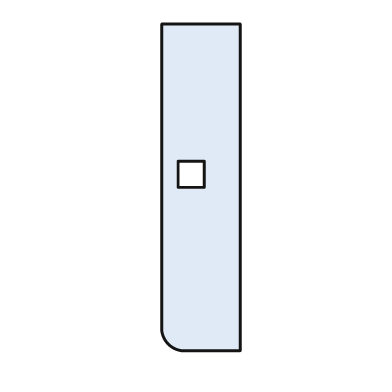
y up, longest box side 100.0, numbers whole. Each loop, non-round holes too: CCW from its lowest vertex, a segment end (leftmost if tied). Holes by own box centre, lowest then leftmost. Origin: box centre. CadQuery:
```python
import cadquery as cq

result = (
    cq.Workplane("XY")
    .moveTo(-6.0, -50.0)
    .lineTo(12.0, -50.0)
    .lineTo(12.0, 50.0)
    .lineTo(-12.0, 50.0)
    .lineTo(-12.0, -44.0)
    .threePointArc((-10.0, -48.0), (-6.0, -50.0))
    .close()
    .moveTo(-7.0, 0.0)
    .lineTo(1.0, 0.0)
    .lineTo(1.0, 8.0)
    .lineTo(-7.0, 8.0)
    .close()
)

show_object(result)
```